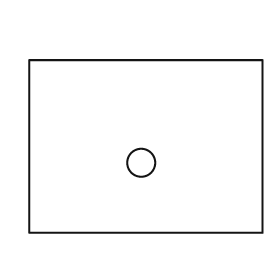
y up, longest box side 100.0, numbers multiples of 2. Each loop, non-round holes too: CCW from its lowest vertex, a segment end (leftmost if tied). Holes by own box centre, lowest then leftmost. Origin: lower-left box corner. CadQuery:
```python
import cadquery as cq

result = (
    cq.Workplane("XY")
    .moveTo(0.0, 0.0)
    .lineTo(100.0, 0.0)
    .lineTo(100.0, 74.0)
    .lineTo(0.0, 74.0)
    .close()
    .moveTo(48.0, 30.0)
    .circle(6.0)
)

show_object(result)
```